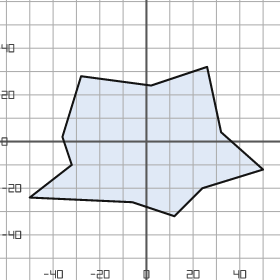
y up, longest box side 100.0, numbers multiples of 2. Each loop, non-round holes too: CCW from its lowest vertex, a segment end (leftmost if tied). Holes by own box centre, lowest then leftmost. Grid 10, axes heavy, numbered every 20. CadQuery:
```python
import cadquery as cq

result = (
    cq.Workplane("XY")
    .moveTo(12.0, -32.0)
    .lineTo(24.0, -20.0)
    .lineTo(50.0, -12.0)
    .lineTo(32.0, 4.0)
    .lineTo(26.0, 32.0)
    .lineTo(2.0, 24.0)
    .lineTo(-28.0, 28.0)
    .lineTo(-36.0, 2.0)
    .lineTo(-32.0, -10.0)
    .lineTo(-50.0, -24.0)
    .lineTo(-6.0, -26.0)
    .close()
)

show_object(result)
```